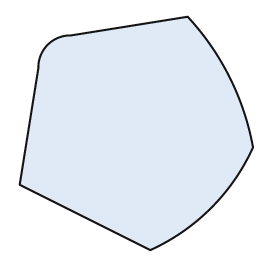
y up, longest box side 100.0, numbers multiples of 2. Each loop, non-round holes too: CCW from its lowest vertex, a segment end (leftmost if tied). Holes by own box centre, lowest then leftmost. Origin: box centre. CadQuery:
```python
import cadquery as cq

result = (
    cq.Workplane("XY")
    .moveTo(6.0, -50.0)
    .threePointArc((32.0, -32.0), (50.0, -6.0))
    .threePointArc((40.0, 24.0), (22.0, 50.0))
    .lineTo(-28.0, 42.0)
    .threePointArc((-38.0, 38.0), (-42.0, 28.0))
    .lineTo(-50.0, -22.0)
    .close()
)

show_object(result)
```